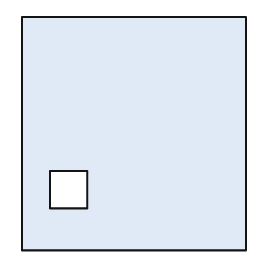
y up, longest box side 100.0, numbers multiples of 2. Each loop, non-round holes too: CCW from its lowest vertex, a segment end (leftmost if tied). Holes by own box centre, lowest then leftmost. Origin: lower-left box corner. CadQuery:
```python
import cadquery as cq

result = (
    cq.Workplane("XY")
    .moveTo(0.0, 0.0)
    .lineTo(96.0, 0.0)
    .lineTo(96.0, 100.0)
    .lineTo(0.0, 100.0)
    .close()
    .moveTo(12.0, 18.0)
    .lineTo(28.0, 18.0)
    .lineTo(28.0, 34.0)
    .lineTo(12.0, 34.0)
    .close()
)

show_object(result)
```